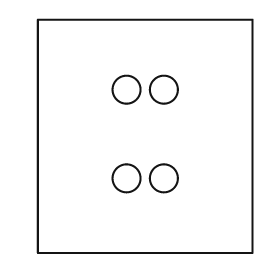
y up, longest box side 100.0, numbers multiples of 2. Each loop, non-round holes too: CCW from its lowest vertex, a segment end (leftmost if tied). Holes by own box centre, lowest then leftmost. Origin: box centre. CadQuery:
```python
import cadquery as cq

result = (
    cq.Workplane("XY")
    .moveTo(-46.0, -50.0)
    .lineTo(46.0, -50.0)
    .lineTo(46.0, 50.0)
    .lineTo(-46.0, 50.0)
    .close()
    .moveTo(-8.0, -18.0)
    .circle(6.0)
    .moveTo(8.0, -18.0)
    .circle(6.0)
    .moveTo(-8.0, 20.0)
    .circle(6.0)
    .moveTo(8.0, 20.0)
    .circle(6.0)
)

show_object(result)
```